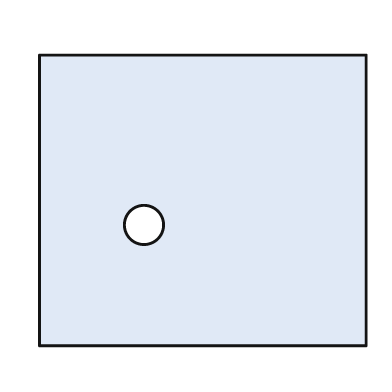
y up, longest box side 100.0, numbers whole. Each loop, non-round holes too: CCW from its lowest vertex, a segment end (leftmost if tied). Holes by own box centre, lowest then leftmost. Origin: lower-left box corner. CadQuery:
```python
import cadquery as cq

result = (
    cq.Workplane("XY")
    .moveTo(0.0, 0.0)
    .lineTo(100.0, 0.0)
    .lineTo(100.0, 89.0)
    .lineTo(0.0, 89.0)
    .close()
    .moveTo(32.0, 37.0)
    .circle(6.0)
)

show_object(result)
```